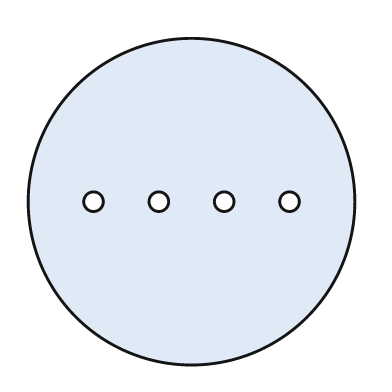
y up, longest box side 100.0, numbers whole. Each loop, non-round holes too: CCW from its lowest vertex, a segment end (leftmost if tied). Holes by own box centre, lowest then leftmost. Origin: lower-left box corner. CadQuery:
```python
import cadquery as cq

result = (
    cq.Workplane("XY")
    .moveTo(50.0, 50.0)
    .circle(50.0)
    .moveTo(20.0, 50.0)
    .circle(3.0)
    .moveTo(40.0, 50.0)
    .circle(3.0)
    .moveTo(60.0, 50.0)
    .circle(3.0)
    .moveTo(80.0, 50.0)
    .circle(3.0)
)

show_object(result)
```